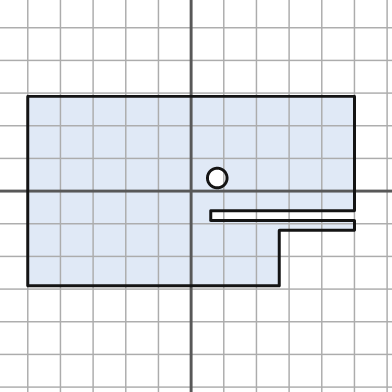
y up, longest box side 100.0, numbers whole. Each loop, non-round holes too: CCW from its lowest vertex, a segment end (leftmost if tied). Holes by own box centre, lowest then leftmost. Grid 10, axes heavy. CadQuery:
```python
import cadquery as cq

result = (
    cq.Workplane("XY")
    .moveTo(-50.0, -29.0)
    .lineTo(27.0, -29.0)
    .lineTo(27.0, -12.0)
    .lineTo(50.0, -12.0)
    .lineTo(50.0, -9.0)
    .lineTo(6.0, -9.0)
    .lineTo(6.0, -6.0)
    .lineTo(50.0, -6.0)
    .lineTo(50.0, 29.0)
    .lineTo(-50.0, 29.0)
    .close()
    .moveTo(8.0, 4.0)
    .circle(3.0)
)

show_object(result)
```